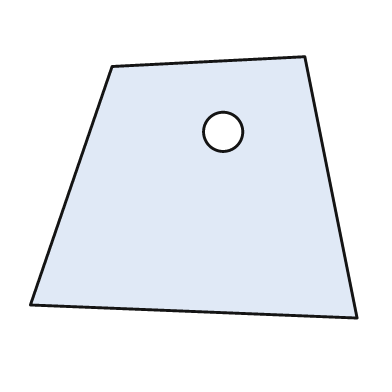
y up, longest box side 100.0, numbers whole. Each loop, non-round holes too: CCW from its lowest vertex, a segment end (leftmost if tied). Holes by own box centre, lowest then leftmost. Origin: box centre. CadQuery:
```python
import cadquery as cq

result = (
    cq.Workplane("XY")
    .moveTo(50.0, -40.0)
    .lineTo(34.0, 40.0)
    .lineTo(-25.0, 37.0)
    .lineTo(-50.0, -36.0)
    .close()
    .moveTo(9.0, 17.0)
    .circle(6.0)
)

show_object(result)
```